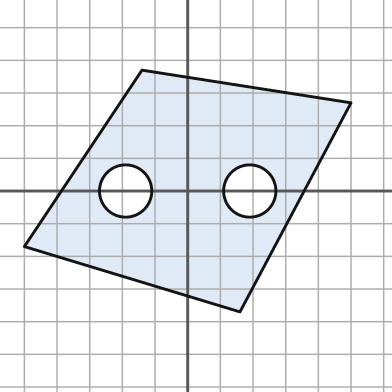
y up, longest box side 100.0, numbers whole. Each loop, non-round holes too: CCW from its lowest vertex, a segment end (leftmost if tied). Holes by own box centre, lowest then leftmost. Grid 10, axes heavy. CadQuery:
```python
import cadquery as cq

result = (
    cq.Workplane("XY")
    .moveTo(16.0, -37.0)
    .lineTo(50.0, 27.0)
    .lineTo(-14.0, 37.0)
    .lineTo(-50.0, -17.0)
    .close()
    .moveTo(-19.0, 0.0)
    .circle(8.0)
    .moveTo(19.0, 0.0)
    .circle(8.0)
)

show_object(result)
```